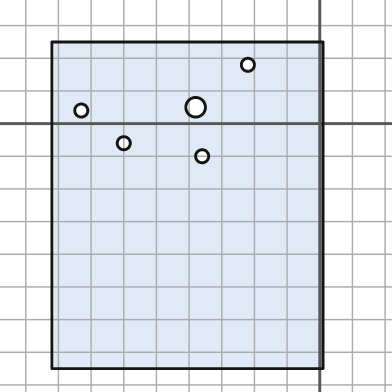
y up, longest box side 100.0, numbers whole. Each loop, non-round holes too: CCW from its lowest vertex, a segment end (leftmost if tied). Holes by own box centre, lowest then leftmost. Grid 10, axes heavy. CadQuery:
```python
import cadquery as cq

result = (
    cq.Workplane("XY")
    .moveTo(-82.0, -75.0)
    .lineTo(1.0, -75.0)
    .lineTo(1.0, 25.0)
    .lineTo(-82.0, 25.0)
    .close()
    .moveTo(-36.0, -10.0)
    .circle(2.0)
    .moveTo(-60.0, -6.0)
    .circle(2.0)
    .moveTo(-73.0, 4.0)
    .circle(2.0)
    .moveTo(-38.0, 5.0)
    .circle(3.0)
    .moveTo(-22.0, 18.0)
    .circle(2.0)
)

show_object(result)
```